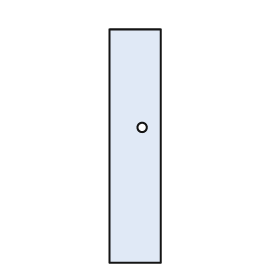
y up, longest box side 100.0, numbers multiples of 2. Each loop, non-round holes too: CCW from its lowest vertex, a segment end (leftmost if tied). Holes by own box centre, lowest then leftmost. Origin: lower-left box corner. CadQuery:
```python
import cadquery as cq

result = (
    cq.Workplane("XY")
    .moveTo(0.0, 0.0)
    .lineTo(22.0, 0.0)
    .lineTo(22.0, 100.0)
    .lineTo(0.0, 100.0)
    .close()
    .moveTo(14.0, 58.0)
    .circle(2.0)
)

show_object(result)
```